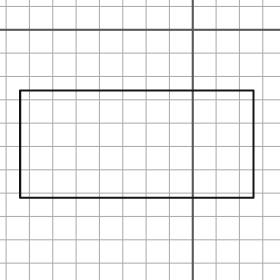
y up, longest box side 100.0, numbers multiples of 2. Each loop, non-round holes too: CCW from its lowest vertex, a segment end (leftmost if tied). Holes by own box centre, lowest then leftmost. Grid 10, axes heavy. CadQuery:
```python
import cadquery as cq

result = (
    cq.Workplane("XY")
    .moveTo(-74.0, -72.0)
    .lineTo(26.0, -72.0)
    .lineTo(26.0, -26.0)
    .lineTo(-74.0, -26.0)
    .close()
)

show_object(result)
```